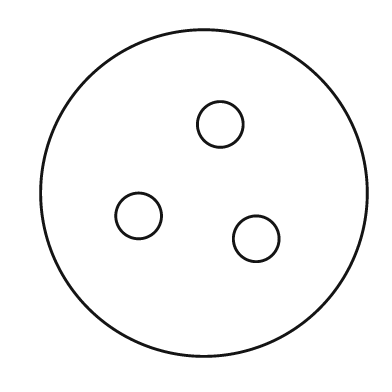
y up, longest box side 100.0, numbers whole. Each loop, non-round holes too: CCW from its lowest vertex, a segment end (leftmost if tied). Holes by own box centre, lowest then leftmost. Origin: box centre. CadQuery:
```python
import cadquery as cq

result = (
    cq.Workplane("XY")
    .moveTo(0.0, 0.0)
    .circle(50.0)
    .moveTo(16.0, -14.0)
    .circle(7.0)
    .moveTo(-20.0, -7.0)
    .circle(7.0)
    .moveTo(5.0, 21.0)
    .circle(7.0)
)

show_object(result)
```